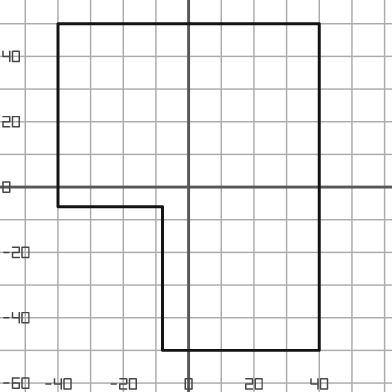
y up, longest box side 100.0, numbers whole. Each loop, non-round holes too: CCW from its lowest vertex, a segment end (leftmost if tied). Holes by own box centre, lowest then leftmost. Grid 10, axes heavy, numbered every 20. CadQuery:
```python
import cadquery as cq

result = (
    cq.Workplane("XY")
    .moveTo(-8.0, -50.0)
    .lineTo(40.0, -50.0)
    .lineTo(40.0, 50.0)
    .lineTo(-40.0, 50.0)
    .lineTo(-40.0, -6.0)
    .lineTo(-8.0, -6.0)
    .close()
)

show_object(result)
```